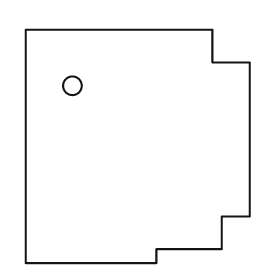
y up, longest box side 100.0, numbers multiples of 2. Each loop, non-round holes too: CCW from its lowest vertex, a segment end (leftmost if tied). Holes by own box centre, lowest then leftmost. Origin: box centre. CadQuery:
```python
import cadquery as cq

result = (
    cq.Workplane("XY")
    .moveTo(-48.0, -50.0)
    .lineTo(8.0, -50.0)
    .lineTo(8.0, -44.0)
    .lineTo(36.0, -44.0)
    .lineTo(36.0, -30.0)
    .lineTo(48.0, -30.0)
    .lineTo(48.0, 36.0)
    .lineTo(32.0, 36.0)
    .lineTo(32.0, 50.0)
    .lineTo(-48.0, 50.0)
    .close()
    .moveTo(-28.0, 26.0)
    .circle(4.0)
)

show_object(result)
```